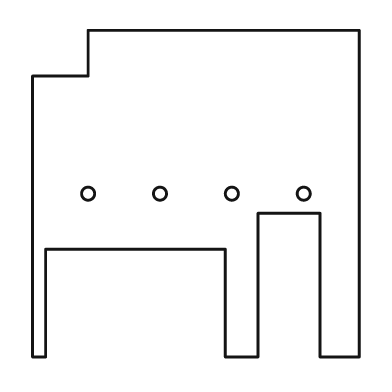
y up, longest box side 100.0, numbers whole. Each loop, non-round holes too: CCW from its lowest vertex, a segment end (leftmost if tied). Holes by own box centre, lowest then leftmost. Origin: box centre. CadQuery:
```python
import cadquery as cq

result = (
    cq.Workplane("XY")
    .moveTo(-50.0, -50.0)
    .lineTo(-46.0, -50.0)
    .lineTo(-46.0, -17.0)
    .lineTo(9.0, -17.0)
    .lineTo(9.0, -50.0)
    .lineTo(19.0, -50.0)
    .lineTo(19.0, -6.0)
    .lineTo(38.0, -6.0)
    .lineTo(38.0, -50.0)
    .lineTo(50.0, -50.0)
    .lineTo(50.0, 50.0)
    .lineTo(-33.0, 50.0)
    .lineTo(-33.0, 36.0)
    .lineTo(-50.0, 36.0)
    .close()
    .moveTo(-33.0, 0.0)
    .circle(2.0)
    .moveTo(-11.0, 0.0)
    .circle(2.0)
    .moveTo(11.0, 0.0)
    .circle(2.0)
    .moveTo(33.0, 0.0)
    .circle(2.0)
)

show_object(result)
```